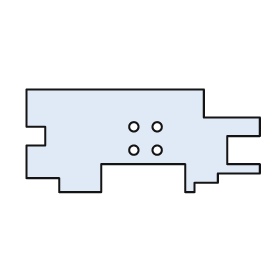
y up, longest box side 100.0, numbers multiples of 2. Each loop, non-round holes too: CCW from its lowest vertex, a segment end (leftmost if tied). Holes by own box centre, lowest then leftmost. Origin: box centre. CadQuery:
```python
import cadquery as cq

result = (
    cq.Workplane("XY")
    .moveTo(-36.0, -22.0)
    .lineTo(-18.0, -22.0)
    .lineTo(-18.0, -10.0)
    .lineTo(18.0, -10.0)
    .lineTo(18.0, -22.0)
    .lineTo(22.0, -22.0)
    .lineTo(22.0, -18.0)
    .lineTo(32.0, -18.0)
    .lineTo(32.0, -14.0)
    .lineTo(50.0, -14.0)
    .lineTo(50.0, -10.0)
    .lineTo(36.0, -10.0)
    .lineTo(36.0, 2.0)
    .lineTo(50.0, 2.0)
    .lineTo(50.0, 10.0)
    .lineTo(26.0, 10.0)
    .lineTo(26.0, 22.0)
    .lineTo(-50.0, 22.0)
    .lineTo(-50.0, 6.0)
    .lineTo(-42.0, 6.0)
    .lineTo(-42.0, -2.0)
    .lineTo(-50.0, -2.0)
    .lineTo(-50.0, -16.0)
    .lineTo(-36.0, -16.0)
    .close()
    .moveTo(-4.0, -4.0)
    .circle(2.0)
    .moveTo(6.0, -4.0)
    .circle(2.0)
    .moveTo(-4.0, 6.0)
    .circle(2.0)
    .moveTo(6.0, 6.0)
    .circle(2.0)
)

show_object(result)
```